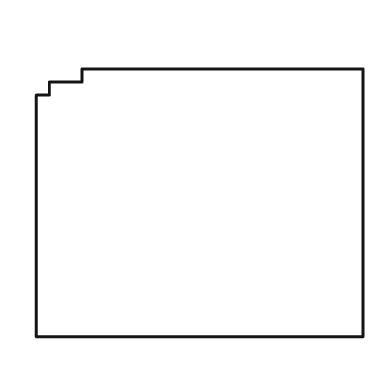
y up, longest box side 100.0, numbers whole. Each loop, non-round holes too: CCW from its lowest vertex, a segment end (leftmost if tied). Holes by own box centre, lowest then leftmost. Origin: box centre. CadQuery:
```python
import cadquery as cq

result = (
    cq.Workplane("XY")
    .moveTo(-50.0, -41.0)
    .lineTo(50.0, -41.0)
    .lineTo(50.0, 41.0)
    .lineTo(-36.0, 41.0)
    .lineTo(-36.0, 37.0)
    .lineTo(-46.0, 37.0)
    .lineTo(-46.0, 33.0)
    .lineTo(-50.0, 33.0)
    .close()
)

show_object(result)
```